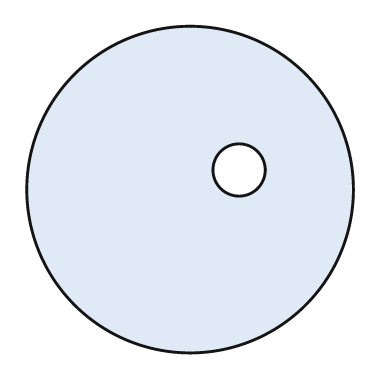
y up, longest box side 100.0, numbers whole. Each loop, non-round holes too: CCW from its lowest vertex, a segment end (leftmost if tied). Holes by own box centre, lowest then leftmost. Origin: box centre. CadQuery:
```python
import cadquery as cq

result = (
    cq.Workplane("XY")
    .moveTo(0.0, 0.0)
    .circle(50.0)
    .moveTo(15.0, 6.0)
    .circle(8.0)
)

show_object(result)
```